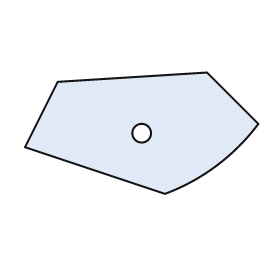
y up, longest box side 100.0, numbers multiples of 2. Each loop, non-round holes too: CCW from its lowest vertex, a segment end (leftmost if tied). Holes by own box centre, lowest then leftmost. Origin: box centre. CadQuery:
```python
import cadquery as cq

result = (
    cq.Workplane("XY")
    .moveTo(10.0, -26.0)
    .threePointArc((32.0, -14.0), (50.0, 4.0))
    .lineTo(28.0, 26.0)
    .lineTo(-36.0, 22.0)
    .lineTo(-50.0, -6.0)
    .close()
    .moveTo(0.0, 0.0)
    .circle(4.0)
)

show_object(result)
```